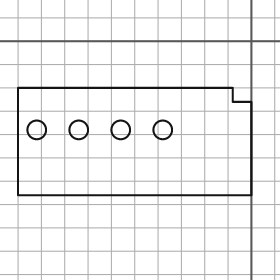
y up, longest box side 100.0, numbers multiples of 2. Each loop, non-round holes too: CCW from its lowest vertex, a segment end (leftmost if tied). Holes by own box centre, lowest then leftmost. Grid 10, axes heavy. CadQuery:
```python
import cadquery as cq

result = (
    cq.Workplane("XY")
    .moveTo(-100.0, -66.0)
    .lineTo(0.0, -66.0)
    .lineTo(0.0, -26.0)
    .lineTo(-8.0, -26.0)
    .lineTo(-8.0, -20.0)
    .lineTo(-100.0, -20.0)
    .close()
    .moveTo(-92.0, -38.0)
    .circle(4.0)
    .moveTo(-74.0, -38.0)
    .circle(4.0)
    .moveTo(-56.0, -38.0)
    .circle(4.0)
    .moveTo(-38.0, -38.0)
    .circle(4.0)
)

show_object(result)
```